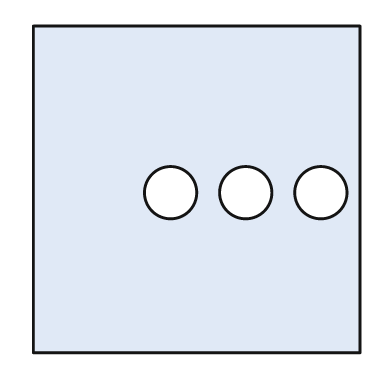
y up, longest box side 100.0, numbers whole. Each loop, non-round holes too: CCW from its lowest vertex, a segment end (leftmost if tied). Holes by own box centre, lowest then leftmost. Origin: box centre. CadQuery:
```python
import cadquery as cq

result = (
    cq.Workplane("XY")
    .moveTo(-50.0, -50.0)
    .lineTo(50.0, -50.0)
    .lineTo(50.0, 50.0)
    .lineTo(-50.0, 50.0)
    .close()
    .moveTo(-8.0, -1.0)
    .circle(8.0)
    .moveTo(15.0, -1.0)
    .circle(8.0)
    .moveTo(38.0, -1.0)
    .circle(8.0)
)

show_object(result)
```